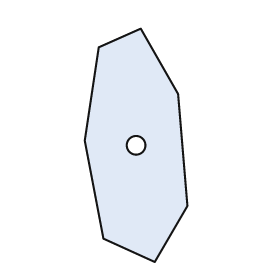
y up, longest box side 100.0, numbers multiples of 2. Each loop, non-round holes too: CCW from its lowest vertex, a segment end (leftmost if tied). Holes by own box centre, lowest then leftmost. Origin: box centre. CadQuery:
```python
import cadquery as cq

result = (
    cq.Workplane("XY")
    .moveTo(8.0, -50.0)
    .lineTo(22.0, -26.0)
    .lineTo(18.0, 22.0)
    .lineTo(2.0, 50.0)
    .lineTo(-16.0, 42.0)
    .lineTo(-22.0, 2.0)
    .lineTo(-14.0, -40.0)
    .close()
    .moveTo(0.0, 0.0)
    .circle(4.0)
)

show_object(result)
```